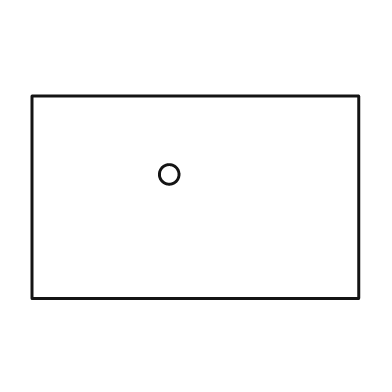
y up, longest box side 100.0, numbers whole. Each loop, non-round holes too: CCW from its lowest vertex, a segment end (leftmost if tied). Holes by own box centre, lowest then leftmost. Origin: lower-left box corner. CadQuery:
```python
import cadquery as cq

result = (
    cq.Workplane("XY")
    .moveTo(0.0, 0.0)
    .lineTo(100.0, 0.0)
    .lineTo(100.0, 62.0)
    .lineTo(0.0, 62.0)
    .close()
    .moveTo(42.0, 38.0)
    .circle(3.0)
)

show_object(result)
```